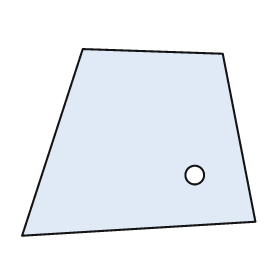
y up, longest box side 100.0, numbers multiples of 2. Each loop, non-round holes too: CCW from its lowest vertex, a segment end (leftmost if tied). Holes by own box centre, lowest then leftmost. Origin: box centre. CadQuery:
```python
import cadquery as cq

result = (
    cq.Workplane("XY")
    .moveTo(-50.0, -40.0)
    .lineTo(50.0, -34.0)
    .lineTo(36.0, 38.0)
    .lineTo(-24.0, 40.0)
    .close()
    .moveTo(24.0, -14.0)
    .circle(4.0)
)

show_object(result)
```